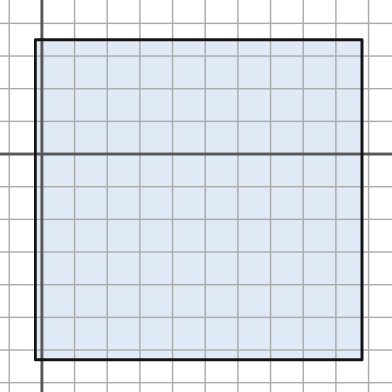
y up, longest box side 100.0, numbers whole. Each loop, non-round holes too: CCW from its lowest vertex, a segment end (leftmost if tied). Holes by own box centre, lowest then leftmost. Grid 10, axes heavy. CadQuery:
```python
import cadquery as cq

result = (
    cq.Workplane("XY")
    .moveTo(-2.0, -63.0)
    .lineTo(98.0, -63.0)
    .lineTo(98.0, 35.0)
    .lineTo(-2.0, 35.0)
    .close()
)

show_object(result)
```